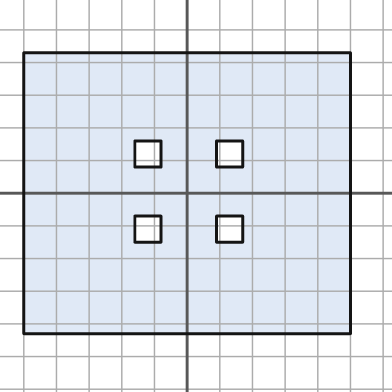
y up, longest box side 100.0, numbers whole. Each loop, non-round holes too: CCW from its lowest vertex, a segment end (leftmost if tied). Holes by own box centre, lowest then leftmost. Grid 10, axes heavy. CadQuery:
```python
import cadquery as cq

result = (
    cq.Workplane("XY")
    .moveTo(-50.0, -43.0)
    .lineTo(50.0, -43.0)
    .lineTo(50.0, 43.0)
    .lineTo(-50.0, 43.0)
    .close()
    .moveTo(-16.0, -15.0)
    .lineTo(-8.0, -15.0)
    .lineTo(-8.0, -7.0)
    .lineTo(-16.0, -7.0)
    .close()
    .moveTo(9.0, -15.0)
    .lineTo(17.0, -15.0)
    .lineTo(17.0, -7.0)
    .lineTo(9.0, -7.0)
    .close()
    .moveTo(-16.0, 8.0)
    .lineTo(-8.0, 8.0)
    .lineTo(-8.0, 16.0)
    .lineTo(-16.0, 16.0)
    .close()
    .moveTo(9.0, 8.0)
    .lineTo(17.0, 8.0)
    .lineTo(17.0, 16.0)
    .lineTo(9.0, 16.0)
    .close()
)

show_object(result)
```